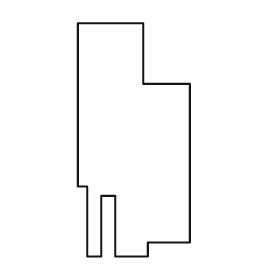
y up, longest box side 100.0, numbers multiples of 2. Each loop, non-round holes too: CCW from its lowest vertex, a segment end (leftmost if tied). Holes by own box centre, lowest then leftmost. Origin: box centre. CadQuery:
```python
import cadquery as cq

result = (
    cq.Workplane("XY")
    .moveTo(-20.0, -50.0)
    .lineTo(-14.0, -50.0)
    .lineTo(-14.0, -24.0)
    .lineTo(-8.0, -24.0)
    .lineTo(-8.0, -50.0)
    .lineTo(6.0, -50.0)
    .lineTo(6.0, -44.0)
    .lineTo(24.0, -44.0)
    .lineTo(24.0, 24.0)
    .lineTo(4.0, 24.0)
    .lineTo(4.0, 50.0)
    .lineTo(-24.0, 50.0)
    .lineTo(-24.0, -20.0)
    .lineTo(-20.0, -20.0)
    .close()
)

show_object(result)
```